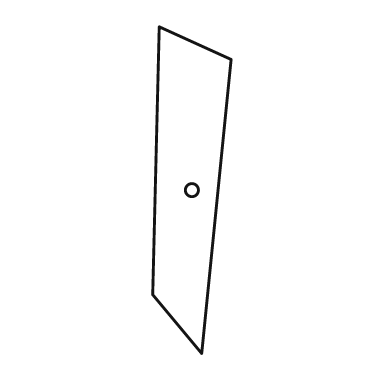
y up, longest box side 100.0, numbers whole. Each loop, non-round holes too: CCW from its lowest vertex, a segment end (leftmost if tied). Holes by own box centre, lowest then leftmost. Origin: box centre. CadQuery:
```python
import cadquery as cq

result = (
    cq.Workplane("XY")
    .moveTo(3.0, -50.0)
    .lineTo(12.0, 40.0)
    .lineTo(-10.0, 50.0)
    .lineTo(-12.0, -32.0)
    .close()
    .moveTo(0.0, 0.0)
    .circle(2.0)
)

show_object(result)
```